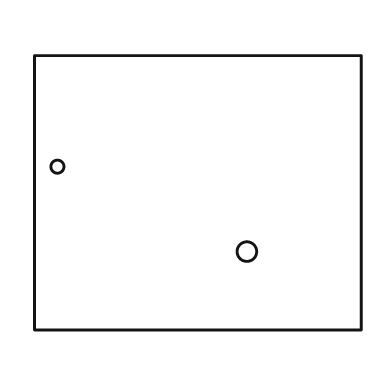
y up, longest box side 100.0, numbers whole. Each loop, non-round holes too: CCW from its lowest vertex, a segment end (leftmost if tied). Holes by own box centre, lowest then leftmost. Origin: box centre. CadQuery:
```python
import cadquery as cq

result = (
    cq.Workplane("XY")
    .moveTo(-50.0, -42.0)
    .lineTo(50.0, -42.0)
    .lineTo(50.0, 42.0)
    .lineTo(-50.0, 42.0)
    .close()
    .moveTo(15.0, -18.0)
    .circle(3.0)
    .moveTo(-43.0, 8.0)
    .circle(2.0)
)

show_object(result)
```